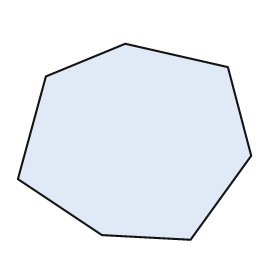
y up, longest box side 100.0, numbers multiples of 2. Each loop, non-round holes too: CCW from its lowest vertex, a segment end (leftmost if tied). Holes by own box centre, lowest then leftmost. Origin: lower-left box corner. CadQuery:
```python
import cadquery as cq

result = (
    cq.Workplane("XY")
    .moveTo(74.0, 0.0)
    .lineTo(100.0, 36.0)
    .lineTo(90.0, 74.0)
    .lineTo(46.0, 84.0)
    .lineTo(12.0, 70.0)
    .lineTo(0.0, 26.0)
    .lineTo(36.0, 2.0)
    .close()
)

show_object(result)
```